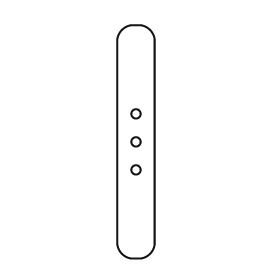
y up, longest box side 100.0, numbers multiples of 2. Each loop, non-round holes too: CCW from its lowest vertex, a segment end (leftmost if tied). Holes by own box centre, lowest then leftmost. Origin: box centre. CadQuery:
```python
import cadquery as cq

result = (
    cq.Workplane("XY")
    .moveTo(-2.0, -50.0)
    .lineTo(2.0, -50.0)
    .threePointArc((6.0, -48.0), (8.0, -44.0))
    .lineTo(8.0, 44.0)
    .threePointArc((6.0, 48.0), (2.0, 50.0))
    .lineTo(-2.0, 50.0)
    .threePointArc((-6.0, 48.0), (-8.0, 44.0))
    .lineTo(-8.0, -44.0)
    .threePointArc((-6.0, -48.0), (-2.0, -50.0))
    .close()
    .moveTo(0.0, -12.0)
    .circle(2.0)
    .moveTo(0.0, 0.0)
    .circle(2.0)
    .moveTo(0.0, 12.0)
    .circle(2.0)
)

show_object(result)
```